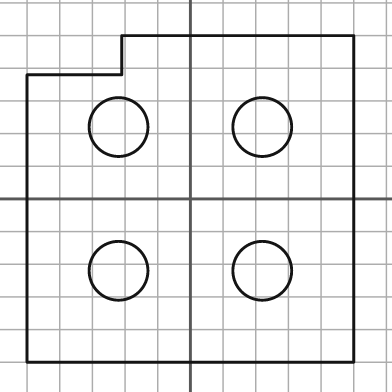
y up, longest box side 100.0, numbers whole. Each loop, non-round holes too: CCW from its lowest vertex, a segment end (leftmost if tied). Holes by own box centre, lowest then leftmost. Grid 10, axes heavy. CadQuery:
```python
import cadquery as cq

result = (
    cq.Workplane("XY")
    .moveTo(-50.0, -50.0)
    .lineTo(50.0, -50.0)
    .lineTo(50.0, 50.0)
    .lineTo(-21.0, 50.0)
    .lineTo(-21.0, 38.0)
    .lineTo(-50.0, 38.0)
    .close()
    .moveTo(-22.0, -22.0)
    .circle(9.0)
    .moveTo(22.0, -22.0)
    .circle(9.0)
    .moveTo(-22.0, 22.0)
    .circle(9.0)
    .moveTo(22.0, 22.0)
    .circle(9.0)
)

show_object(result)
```